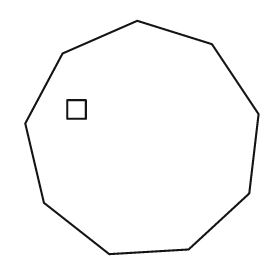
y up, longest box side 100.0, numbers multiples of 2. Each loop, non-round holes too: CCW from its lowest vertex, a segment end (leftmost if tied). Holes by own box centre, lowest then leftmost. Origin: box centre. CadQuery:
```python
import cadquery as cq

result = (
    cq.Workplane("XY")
    .moveTo(-14.0, -50.0)
    .lineTo(20.0, -48.0)
    .lineTo(46.0, -24.0)
    .lineTo(50.0, 10.0)
    .lineTo(30.0, 40.0)
    .lineTo(-2.0, 50.0)
    .lineTo(-34.0, 36.0)
    .lineTo(-50.0, 6.0)
    .lineTo(-42.0, -28.0)
    .close()
    .moveTo(-32.0, 8.0)
    .lineTo(-24.0, 8.0)
    .lineTo(-24.0, 16.0)
    .lineTo(-32.0, 16.0)
    .close()
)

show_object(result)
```